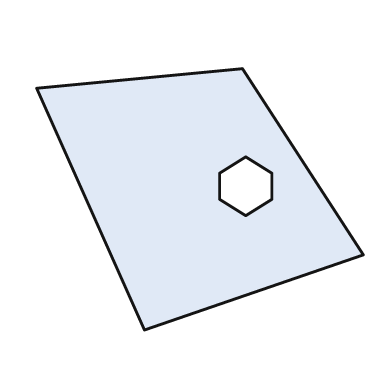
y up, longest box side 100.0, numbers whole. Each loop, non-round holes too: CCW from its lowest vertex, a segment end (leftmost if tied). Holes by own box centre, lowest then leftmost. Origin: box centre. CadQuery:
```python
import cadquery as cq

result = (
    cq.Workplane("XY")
    .moveTo(-17.0, -40.0)
    .lineTo(50.0, -17.0)
    .lineTo(13.0, 40.0)
    .lineTo(-50.0, 34.0)
    .close()
    .moveTo(14.0, -5.0)
    .lineTo(22.0, 0.0)
    .lineTo(22.0, 8.0)
    .lineTo(14.0, 13.0)
    .lineTo(6.0, 8.0)
    .lineTo(6.0, 0.0)
    .close()
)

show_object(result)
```